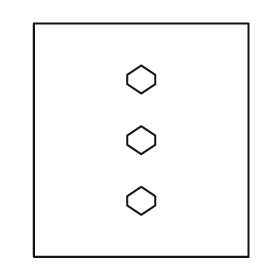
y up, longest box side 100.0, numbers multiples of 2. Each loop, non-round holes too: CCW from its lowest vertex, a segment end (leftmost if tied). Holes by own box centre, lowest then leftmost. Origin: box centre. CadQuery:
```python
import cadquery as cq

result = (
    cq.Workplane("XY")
    .moveTo(-46.0, -50.0)
    .lineTo(46.0, -50.0)
    .lineTo(46.0, 50.0)
    .lineTo(-46.0, 50.0)
    .close()
    .moveTo(0.0, -32.0)
    .lineTo(6.0, -28.0)
    .lineTo(6.0, -24.0)
    .lineTo(0.0, -20.0)
    .lineTo(-6.0, -24.0)
    .lineTo(-6.0, -28.0)
    .close()
    .moveTo(0.0, -6.0)
    .lineTo(6.0, -2.0)
    .lineTo(6.0, 2.0)
    .lineTo(0.0, 6.0)
    .lineTo(-6.0, 2.0)
    .lineTo(-6.0, -2.0)
    .close()
    .moveTo(0.0, 20.0)
    .lineTo(6.0, 24.0)
    .lineTo(6.0, 28.0)
    .lineTo(0.0, 32.0)
    .lineTo(-6.0, 28.0)
    .lineTo(-6.0, 24.0)
    .close()
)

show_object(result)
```